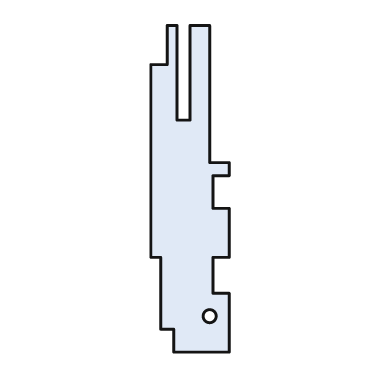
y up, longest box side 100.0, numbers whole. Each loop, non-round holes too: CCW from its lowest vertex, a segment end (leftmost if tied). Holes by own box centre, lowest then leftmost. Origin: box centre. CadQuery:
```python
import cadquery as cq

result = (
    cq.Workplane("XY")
    .moveTo(-5.0, -50.0)
    .lineTo(12.0, -50.0)
    .lineTo(12.0, -32.0)
    .lineTo(7.0, -32.0)
    .lineTo(7.0, -21.0)
    .lineTo(12.0, -21.0)
    .lineTo(12.0, -6.0)
    .lineTo(7.0, -6.0)
    .lineTo(7.0, 4.0)
    .lineTo(12.0, 4.0)
    .lineTo(12.0, 8.0)
    .lineTo(6.0, 8.0)
    .lineTo(6.0, 50.0)
    .lineTo(0.0, 50.0)
    .lineTo(0.0, 21.0)
    .lineTo(-4.0, 21.0)
    .lineTo(-4.0, 50.0)
    .lineTo(-7.0, 50.0)
    .lineTo(-7.0, 38.0)
    .lineTo(-12.0, 38.0)
    .lineTo(-12.0, -21.0)
    .lineTo(-9.0, -21.0)
    .lineTo(-9.0, -43.0)
    .lineTo(-5.0, -43.0)
    .close()
    .moveTo(6.0, -39.0)
    .circle(2.0)
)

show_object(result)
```